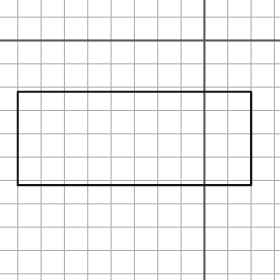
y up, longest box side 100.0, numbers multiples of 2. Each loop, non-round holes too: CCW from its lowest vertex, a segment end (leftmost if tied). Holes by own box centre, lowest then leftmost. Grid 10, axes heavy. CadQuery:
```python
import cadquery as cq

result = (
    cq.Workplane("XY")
    .moveTo(-80.0, -62.0)
    .lineTo(20.0, -62.0)
    .lineTo(20.0, -22.0)
    .lineTo(-80.0, -22.0)
    .close()
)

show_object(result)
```